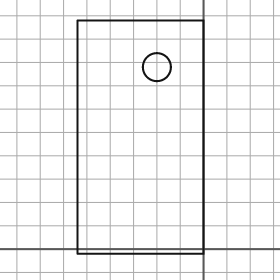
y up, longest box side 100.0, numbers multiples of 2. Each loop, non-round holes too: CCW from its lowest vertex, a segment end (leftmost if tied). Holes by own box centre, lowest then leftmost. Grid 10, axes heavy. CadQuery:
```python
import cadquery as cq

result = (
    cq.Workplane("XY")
    .moveTo(-54.0, -2.0)
    .lineTo(0.0, -2.0)
    .lineTo(0.0, 98.0)
    .lineTo(-54.0, 98.0)
    .close()
    .moveTo(-20.0, 78.0)
    .circle(6.0)
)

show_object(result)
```